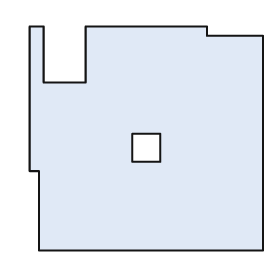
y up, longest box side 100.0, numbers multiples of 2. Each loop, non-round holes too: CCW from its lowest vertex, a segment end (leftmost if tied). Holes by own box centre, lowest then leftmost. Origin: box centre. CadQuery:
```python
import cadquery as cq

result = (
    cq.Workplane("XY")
    .moveTo(-46.0, -48.0)
    .lineTo(50.0, -48.0)
    .lineTo(50.0, 44.0)
    .lineTo(26.0, 44.0)
    .lineTo(26.0, 48.0)
    .lineTo(-26.0, 48.0)
    .lineTo(-26.0, 24.0)
    .lineTo(-44.0, 24.0)
    .lineTo(-44.0, 48.0)
    .lineTo(-50.0, 48.0)
    .lineTo(-50.0, -14.0)
    .lineTo(-46.0, -14.0)
    .close()
    .moveTo(-6.0, -10.0)
    .lineTo(6.0, -10.0)
    .lineTo(6.0, 2.0)
    .lineTo(-6.0, 2.0)
    .close()
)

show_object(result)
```